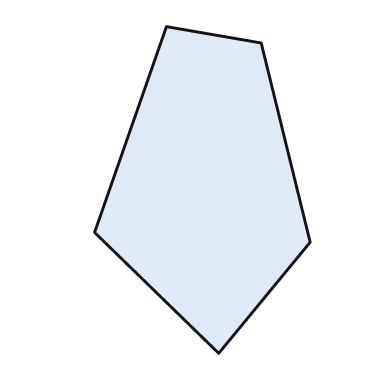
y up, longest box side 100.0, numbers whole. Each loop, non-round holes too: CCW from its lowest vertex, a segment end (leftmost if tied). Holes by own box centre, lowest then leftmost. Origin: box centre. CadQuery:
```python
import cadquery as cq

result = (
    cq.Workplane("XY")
    .moveTo(5.0, -50.0)
    .lineTo(33.0, -16.0)
    .lineTo(18.0, 45.0)
    .lineTo(-11.0, 50.0)
    .lineTo(-33.0, -13.0)
    .close()
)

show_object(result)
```